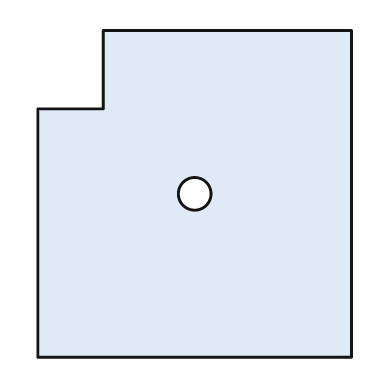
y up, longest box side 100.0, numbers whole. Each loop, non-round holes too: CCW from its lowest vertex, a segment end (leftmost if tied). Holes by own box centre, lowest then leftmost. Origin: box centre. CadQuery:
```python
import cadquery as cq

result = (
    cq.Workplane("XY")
    .moveTo(-48.0, -50.0)
    .lineTo(48.0, -50.0)
    .lineTo(48.0, 50.0)
    .lineTo(-28.0, 50.0)
    .lineTo(-28.0, 26.0)
    .lineTo(-48.0, 26.0)
    .close()
    .moveTo(0.0, 0.0)
    .circle(5.0)
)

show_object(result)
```